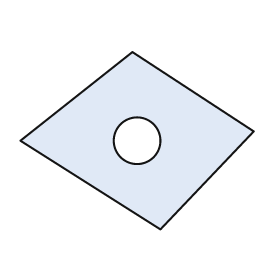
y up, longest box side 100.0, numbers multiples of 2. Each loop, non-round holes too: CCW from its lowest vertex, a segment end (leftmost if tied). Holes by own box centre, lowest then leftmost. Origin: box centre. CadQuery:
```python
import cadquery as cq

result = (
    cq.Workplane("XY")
    .moveTo(10.0, -38.0)
    .lineTo(50.0, 4.0)
    .lineTo(-2.0, 38.0)
    .lineTo(-50.0, 0.0)
    .close()
    .moveTo(0.0, 0.0)
    .circle(10.0)
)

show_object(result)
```